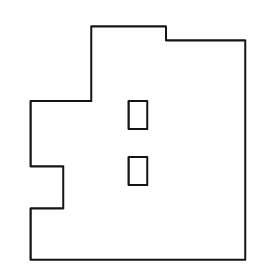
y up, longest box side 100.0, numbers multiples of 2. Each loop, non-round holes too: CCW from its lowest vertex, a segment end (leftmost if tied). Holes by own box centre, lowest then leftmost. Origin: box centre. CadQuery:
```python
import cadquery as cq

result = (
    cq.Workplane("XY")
    .moveTo(-46.0, -50.0)
    .lineTo(46.0, -50.0)
    .lineTo(46.0, 44.0)
    .lineTo(12.0, 44.0)
    .lineTo(12.0, 50.0)
    .lineTo(-20.0, 50.0)
    .lineTo(-20.0, 18.0)
    .lineTo(-46.0, 18.0)
    .lineTo(-46.0, -10.0)
    .lineTo(-32.0, -10.0)
    .lineTo(-32.0, -28.0)
    .lineTo(-46.0, -28.0)
    .close()
    .moveTo(-4.0, -18.0)
    .lineTo(4.0, -18.0)
    .lineTo(4.0, -6.0)
    .lineTo(-4.0, -6.0)
    .close()
    .moveTo(-4.0, 6.0)
    .lineTo(4.0, 6.0)
    .lineTo(4.0, 18.0)
    .lineTo(-4.0, 18.0)
    .close()
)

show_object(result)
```